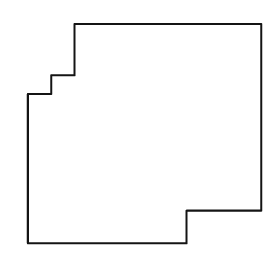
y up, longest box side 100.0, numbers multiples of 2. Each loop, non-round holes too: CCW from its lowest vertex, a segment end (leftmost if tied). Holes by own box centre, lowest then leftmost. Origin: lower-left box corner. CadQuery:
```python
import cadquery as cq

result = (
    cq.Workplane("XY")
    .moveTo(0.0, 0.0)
    .lineTo(68.0, 0.0)
    .lineTo(68.0, 14.0)
    .lineTo(100.0, 14.0)
    .lineTo(100.0, 94.0)
    .lineTo(20.0, 94.0)
    .lineTo(20.0, 72.0)
    .lineTo(10.0, 72.0)
    .lineTo(10.0, 64.0)
    .lineTo(0.0, 64.0)
    .close()
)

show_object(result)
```